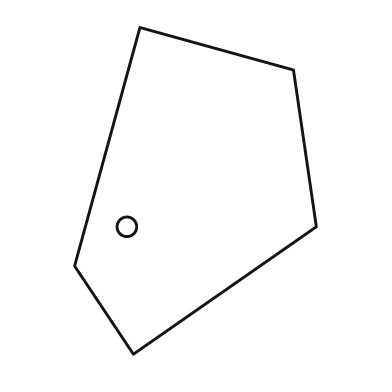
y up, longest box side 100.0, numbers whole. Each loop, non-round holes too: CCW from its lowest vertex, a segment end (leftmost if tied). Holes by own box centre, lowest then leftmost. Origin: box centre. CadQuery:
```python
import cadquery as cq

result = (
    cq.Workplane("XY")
    .moveTo(-19.0, -50.0)
    .lineTo(37.0, -11.0)
    .lineTo(30.0, 37.0)
    .lineTo(-17.0, 50.0)
    .lineTo(-37.0, -23.0)
    .close()
    .moveTo(-21.0, -11.0)
    .circle(3.0)
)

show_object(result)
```